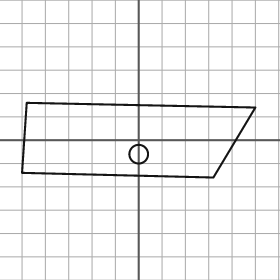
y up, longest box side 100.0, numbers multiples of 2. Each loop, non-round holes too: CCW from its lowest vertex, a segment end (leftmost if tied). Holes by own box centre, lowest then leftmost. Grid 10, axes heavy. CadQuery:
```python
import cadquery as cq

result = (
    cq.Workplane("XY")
    .moveTo(32.0, -16.0)
    .lineTo(50.0, 14.0)
    .lineTo(-48.0, 16.0)
    .lineTo(-50.0, -14.0)
    .close()
    .moveTo(0.0, -6.0)
    .circle(4.0)
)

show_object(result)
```